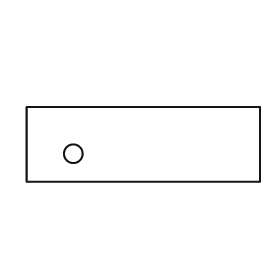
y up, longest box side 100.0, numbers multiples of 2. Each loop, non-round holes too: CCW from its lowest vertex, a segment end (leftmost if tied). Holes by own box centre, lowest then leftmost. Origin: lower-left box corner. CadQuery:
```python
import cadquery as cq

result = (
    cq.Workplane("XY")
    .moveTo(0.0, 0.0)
    .lineTo(100.0, 0.0)
    .lineTo(100.0, 32.0)
    .lineTo(0.0, 32.0)
    .close()
    .moveTo(20.0, 12.0)
    .circle(4.0)
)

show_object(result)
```